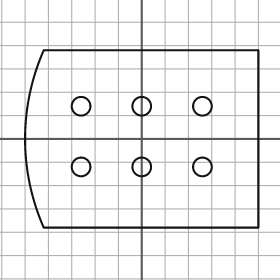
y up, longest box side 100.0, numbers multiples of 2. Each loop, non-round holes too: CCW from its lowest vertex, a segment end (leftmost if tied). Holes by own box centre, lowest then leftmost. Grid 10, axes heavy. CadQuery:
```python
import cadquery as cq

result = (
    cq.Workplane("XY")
    .moveTo(-42.0, -38.0)
    .lineTo(50.0, -38.0)
    .lineTo(50.0, 38.0)
    .lineTo(-42.0, 38.0)
    .threePointArc((-50.0, 0.0), (-42.0, -38.0))
    .close()
    .moveTo(-26.0, -12.0)
    .circle(4.0)
    .moveTo(0.0, -12.0)
    .circle(4.0)
    .moveTo(26.0, -12.0)
    .circle(4.0)
    .moveTo(-26.0, 14.0)
    .circle(4.0)
    .moveTo(0.0, 14.0)
    .circle(4.0)
    .moveTo(26.0, 14.0)
    .circle(4.0)
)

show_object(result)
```